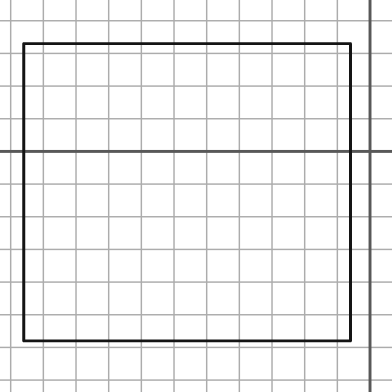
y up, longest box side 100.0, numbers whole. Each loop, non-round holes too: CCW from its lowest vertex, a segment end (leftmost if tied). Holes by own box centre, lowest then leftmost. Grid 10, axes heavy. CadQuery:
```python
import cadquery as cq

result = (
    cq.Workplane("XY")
    .moveTo(-106.0, -58.0)
    .lineTo(-6.0, -58.0)
    .lineTo(-6.0, 33.0)
    .lineTo(-106.0, 33.0)
    .close()
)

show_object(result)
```